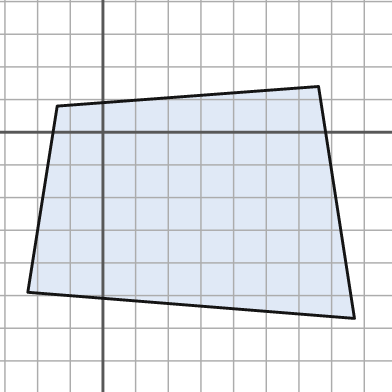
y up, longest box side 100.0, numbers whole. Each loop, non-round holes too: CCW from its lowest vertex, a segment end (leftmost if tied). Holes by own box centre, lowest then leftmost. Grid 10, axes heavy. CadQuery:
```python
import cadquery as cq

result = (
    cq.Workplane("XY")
    .moveTo(77.0, -57.0)
    .lineTo(66.0, 14.0)
    .lineTo(-14.0, 8.0)
    .lineTo(-23.0, -49.0)
    .close()
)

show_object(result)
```